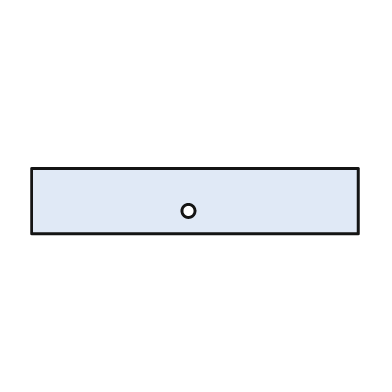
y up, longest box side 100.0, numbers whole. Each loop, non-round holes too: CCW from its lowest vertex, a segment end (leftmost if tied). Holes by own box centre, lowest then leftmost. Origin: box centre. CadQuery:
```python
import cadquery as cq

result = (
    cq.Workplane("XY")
    .moveTo(-50.0, -10.0)
    .lineTo(50.0, -10.0)
    .lineTo(50.0, 10.0)
    .lineTo(-50.0, 10.0)
    .close()
    .moveTo(-2.0, -3.0)
    .circle(2.0)
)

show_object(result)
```